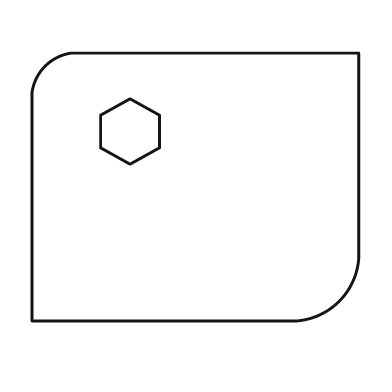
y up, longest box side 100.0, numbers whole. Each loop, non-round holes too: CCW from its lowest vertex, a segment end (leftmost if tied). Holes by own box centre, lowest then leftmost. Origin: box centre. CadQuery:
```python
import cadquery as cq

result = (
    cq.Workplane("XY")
    .moveTo(-50.0, -41.0)
    .lineTo(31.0, -41.0)
    .threePointArc((44.0, -35.0), (50.0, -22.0))
    .lineTo(50.0, 41.0)
    .lineTo(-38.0, 41.0)
    .threePointArc((-46.0, 37.0), (-50.0, 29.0))
    .close()
    .moveTo(-20.0, 7.0)
    .lineTo(-11.0, 12.0)
    .lineTo(-11.0, 22.0)
    .lineTo(-20.0, 27.0)
    .lineTo(-29.0, 22.0)
    .lineTo(-29.0, 12.0)
    .close()
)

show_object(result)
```